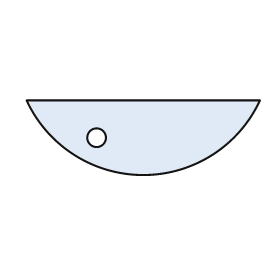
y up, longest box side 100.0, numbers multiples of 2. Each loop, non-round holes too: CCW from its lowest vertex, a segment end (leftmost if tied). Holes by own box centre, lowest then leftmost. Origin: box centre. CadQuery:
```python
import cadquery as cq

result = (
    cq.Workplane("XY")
    .moveTo(-50.0, 16.0)
    .threePointArc((0.0, -16.0), (50.0, 16.0))
    .close()
    .moveTo(-20.0, 0.0)
    .circle(4.0)
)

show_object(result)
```